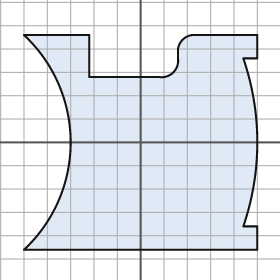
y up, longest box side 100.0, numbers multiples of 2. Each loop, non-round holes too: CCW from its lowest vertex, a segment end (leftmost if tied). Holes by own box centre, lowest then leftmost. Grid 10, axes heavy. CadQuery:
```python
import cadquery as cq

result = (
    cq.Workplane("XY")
    .moveTo(-50.0, -46.0)
    .lineTo(50.0, -46.0)
    .lineTo(50.0, -36.0)
    .lineTo(44.0, -36.0)
    .threePointArc((50.0, 0.0), (44.0, 36.0))
    .lineTo(50.0, 36.0)
    .lineTo(50.0, 46.0)
    .lineTo(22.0, 46.0)
    .threePointArc((18.0, 44.0), (16.0, 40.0))
    .lineTo(16.0, 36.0)
    .threePointArc((14.0, 30.0), (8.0, 28.0))
    .lineTo(-22.0, 28.0)
    .lineTo(-22.0, 46.0)
    .lineTo(-50.0, 46.0)
    .threePointArc((-30.0, 0.0), (-50.0, -46.0))
    .close()
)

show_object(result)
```